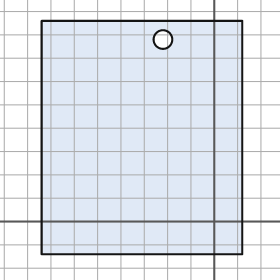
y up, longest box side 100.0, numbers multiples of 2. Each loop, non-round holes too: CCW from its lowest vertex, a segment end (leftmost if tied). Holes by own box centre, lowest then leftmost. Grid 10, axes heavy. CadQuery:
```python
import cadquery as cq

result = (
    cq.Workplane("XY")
    .moveTo(-74.0, -14.0)
    .lineTo(12.0, -14.0)
    .lineTo(12.0, 86.0)
    .lineTo(-74.0, 86.0)
    .close()
    .moveTo(-22.0, 78.0)
    .circle(4.0)
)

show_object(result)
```